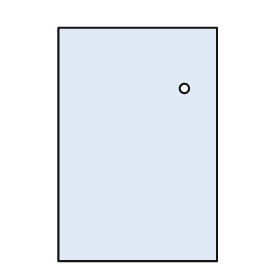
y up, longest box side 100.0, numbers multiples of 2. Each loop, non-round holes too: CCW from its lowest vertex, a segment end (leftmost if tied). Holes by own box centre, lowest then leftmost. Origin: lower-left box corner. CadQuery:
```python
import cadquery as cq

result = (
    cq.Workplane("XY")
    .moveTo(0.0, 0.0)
    .lineTo(68.0, 0.0)
    .lineTo(68.0, 100.0)
    .lineTo(0.0, 100.0)
    .close()
    .moveTo(54.0, 74.0)
    .circle(2.0)
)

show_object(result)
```